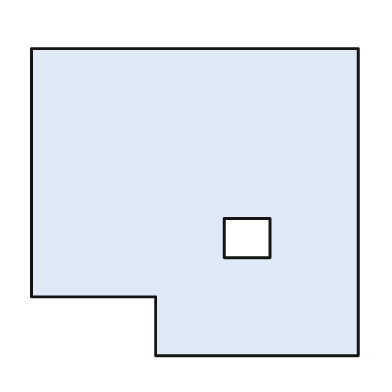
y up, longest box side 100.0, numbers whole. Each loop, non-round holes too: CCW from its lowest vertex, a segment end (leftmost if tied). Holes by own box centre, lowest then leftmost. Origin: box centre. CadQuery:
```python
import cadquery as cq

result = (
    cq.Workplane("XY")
    .moveTo(-12.0, -47.0)
    .lineTo(50.0, -47.0)
    .lineTo(50.0, 47.0)
    .lineTo(-50.0, 47.0)
    .lineTo(-50.0, -29.0)
    .lineTo(-12.0, -29.0)
    .close()
    .moveTo(9.0, -17.0)
    .lineTo(23.0, -17.0)
    .lineTo(23.0, -5.0)
    .lineTo(9.0, -5.0)
    .close()
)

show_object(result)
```